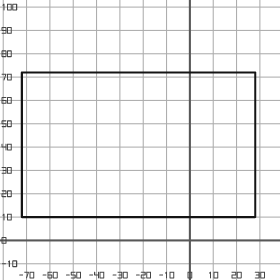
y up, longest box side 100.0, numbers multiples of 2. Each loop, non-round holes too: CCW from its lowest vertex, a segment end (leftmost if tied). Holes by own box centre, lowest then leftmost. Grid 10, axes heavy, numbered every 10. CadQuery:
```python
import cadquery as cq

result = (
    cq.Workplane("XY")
    .moveTo(-72.0, 10.0)
    .lineTo(28.0, 10.0)
    .lineTo(28.0, 72.0)
    .lineTo(-72.0, 72.0)
    .close()
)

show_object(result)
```